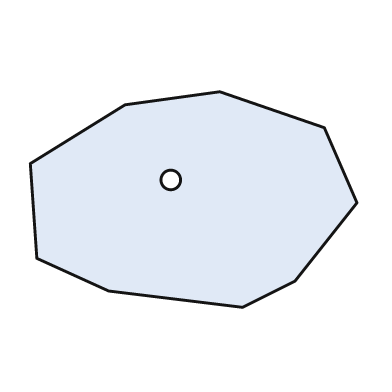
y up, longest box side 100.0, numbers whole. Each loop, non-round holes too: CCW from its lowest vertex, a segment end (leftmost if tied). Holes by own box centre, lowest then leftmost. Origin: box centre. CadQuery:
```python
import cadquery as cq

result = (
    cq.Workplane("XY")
    .moveTo(15.0, -33.0)
    .lineTo(31.0, -25.0)
    .lineTo(50.0, -1.0)
    .lineTo(40.0, 22.0)
    .lineTo(8.0, 33.0)
    .lineTo(-21.0, 29.0)
    .lineTo(-50.0, 11.0)
    .lineTo(-48.0, -18.0)
    .lineTo(-26.0, -28.0)
    .close()
    .moveTo(-7.0, 6.0)
    .circle(3.0)
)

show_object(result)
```